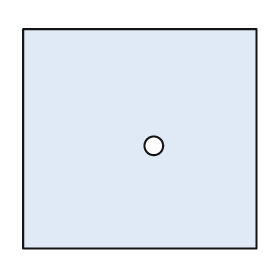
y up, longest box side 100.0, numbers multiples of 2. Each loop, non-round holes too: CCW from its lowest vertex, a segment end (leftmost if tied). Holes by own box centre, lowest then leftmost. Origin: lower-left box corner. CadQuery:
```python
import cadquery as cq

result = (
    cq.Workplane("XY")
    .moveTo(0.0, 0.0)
    .lineTo(100.0, 0.0)
    .lineTo(100.0, 94.0)
    .lineTo(0.0, 94.0)
    .close()
    .moveTo(56.0, 44.0)
    .circle(4.0)
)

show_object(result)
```